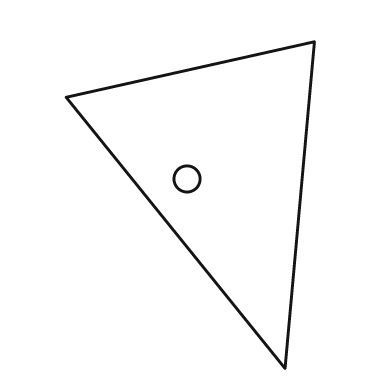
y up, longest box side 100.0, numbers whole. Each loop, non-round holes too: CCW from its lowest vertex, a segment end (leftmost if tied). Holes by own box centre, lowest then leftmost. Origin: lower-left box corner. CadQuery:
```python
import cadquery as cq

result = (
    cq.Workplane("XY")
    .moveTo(67.0, 0.0)
    .lineTo(76.0, 100.0)
    .lineTo(0.0, 83.0)
    .close()
    .moveTo(37.0, 58.0)
    .circle(4.0)
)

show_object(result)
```